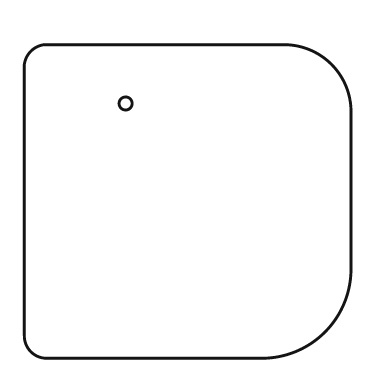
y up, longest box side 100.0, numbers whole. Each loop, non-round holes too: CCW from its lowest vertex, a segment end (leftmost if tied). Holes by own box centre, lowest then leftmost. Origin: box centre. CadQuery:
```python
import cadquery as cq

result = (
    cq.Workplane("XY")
    .moveTo(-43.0, -48.0)
    .lineTo(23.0, -48.0)
    .threePointArc((42.0, -40.0), (50.0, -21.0))
    .lineTo(50.0, 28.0)
    .threePointArc((44.0, 42.0), (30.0, 48.0))
    .lineTo(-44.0, 48.0)
    .threePointArc((-48.0, 46.0), (-50.0, 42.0))
    .lineTo(-50.0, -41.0)
    .threePointArc((-48.0, -46.0), (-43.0, -48.0))
    .close()
    .moveTo(-19.0, 30.0)
    .circle(2.0)
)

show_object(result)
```